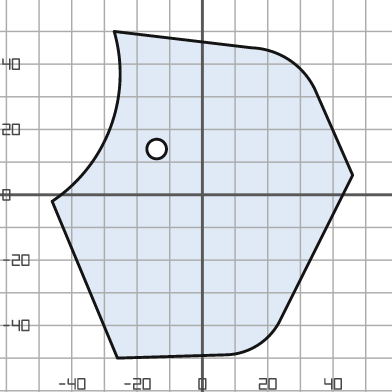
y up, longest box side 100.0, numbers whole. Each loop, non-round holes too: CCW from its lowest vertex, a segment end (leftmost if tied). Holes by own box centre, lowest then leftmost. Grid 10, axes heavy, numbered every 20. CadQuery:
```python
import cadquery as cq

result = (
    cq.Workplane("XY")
    .moveTo(-26.0, -50.0)
    .lineTo(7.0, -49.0)
    .threePointArc((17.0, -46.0), (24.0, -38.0))
    .lineTo(46.0, 6.0)
    .lineTo(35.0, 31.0)
    .threePointArc((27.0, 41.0), (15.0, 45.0))
    .lineTo(-27.0, 50.0)
    .threePointArc((-28.0, 21.0), (-46.0, -2.0))
    .close()
    .moveTo(-14.0, 14.0)
    .circle(3.0)
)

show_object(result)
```